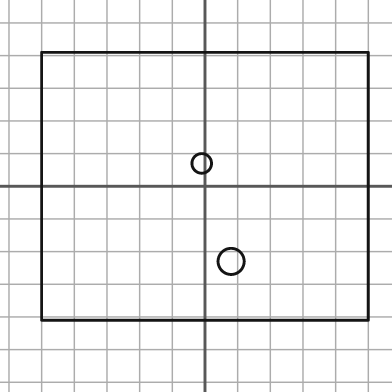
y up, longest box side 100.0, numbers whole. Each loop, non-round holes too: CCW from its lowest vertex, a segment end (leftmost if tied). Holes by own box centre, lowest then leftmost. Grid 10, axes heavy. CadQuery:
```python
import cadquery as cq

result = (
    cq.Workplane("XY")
    .moveTo(-50.0, -41.0)
    .lineTo(50.0, -41.0)
    .lineTo(50.0, 41.0)
    .lineTo(-50.0, 41.0)
    .close()
    .moveTo(8.0, -23.0)
    .circle(4.0)
    .moveTo(-1.0, 7.0)
    .circle(3.0)
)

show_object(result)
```